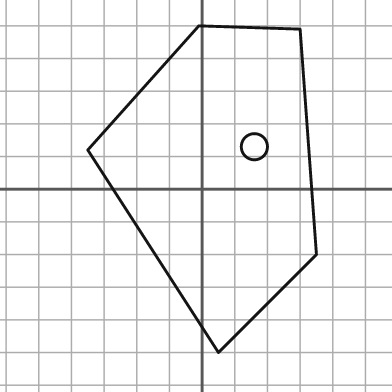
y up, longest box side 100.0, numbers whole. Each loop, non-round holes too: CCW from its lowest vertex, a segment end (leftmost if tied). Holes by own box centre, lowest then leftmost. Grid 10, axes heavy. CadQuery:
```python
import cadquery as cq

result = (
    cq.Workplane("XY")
    .moveTo(5.0, -50.0)
    .lineTo(35.0, -20.0)
    .lineTo(30.0, 49.0)
    .lineTo(-1.0, 50.0)
    .lineTo(-35.0, 12.0)
    .close()
    .moveTo(16.0, 13.0)
    .circle(4.0)
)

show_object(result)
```